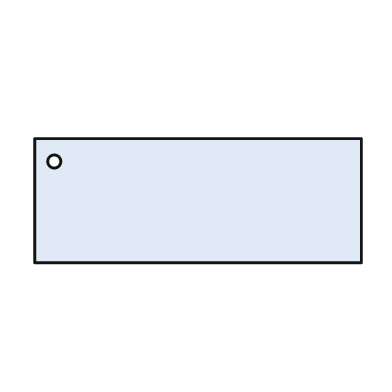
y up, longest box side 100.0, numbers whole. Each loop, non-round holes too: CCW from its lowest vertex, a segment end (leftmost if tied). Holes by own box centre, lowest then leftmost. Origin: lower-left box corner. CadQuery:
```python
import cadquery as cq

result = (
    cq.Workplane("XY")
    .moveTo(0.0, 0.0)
    .lineTo(100.0, 0.0)
    .lineTo(100.0, 38.0)
    .lineTo(0.0, 38.0)
    .close()
    .moveTo(6.0, 31.0)
    .circle(2.0)
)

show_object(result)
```